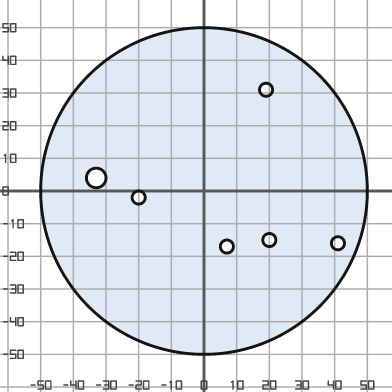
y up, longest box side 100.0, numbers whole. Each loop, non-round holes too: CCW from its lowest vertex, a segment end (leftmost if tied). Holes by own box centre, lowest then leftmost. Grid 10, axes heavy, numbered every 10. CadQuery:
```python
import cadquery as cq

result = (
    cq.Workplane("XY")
    .moveTo(0.0, 0.0)
    .circle(50.0)
    .moveTo(7.0, -17.0)
    .circle(2.0)
    .moveTo(41.0, -16.0)
    .circle(2.0)
    .moveTo(20.0, -15.0)
    .circle(2.0)
    .moveTo(-20.0, -2.0)
    .circle(2.0)
    .moveTo(-33.0, 4.0)
    .circle(3.0)
    .moveTo(19.0, 31.0)
    .circle(2.0)
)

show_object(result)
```